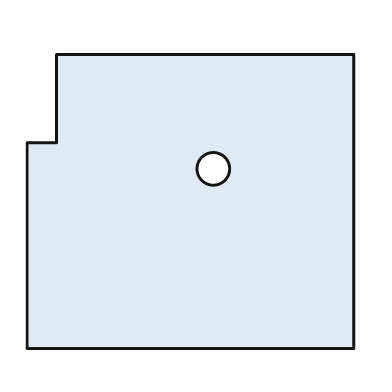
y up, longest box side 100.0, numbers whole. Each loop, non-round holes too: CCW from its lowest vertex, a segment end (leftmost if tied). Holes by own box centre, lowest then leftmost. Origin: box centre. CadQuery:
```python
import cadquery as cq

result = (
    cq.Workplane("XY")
    .moveTo(-50.0, -45.0)
    .lineTo(50.0, -45.0)
    .lineTo(50.0, 45.0)
    .lineTo(-41.0, 45.0)
    .lineTo(-41.0, 18.0)
    .lineTo(-50.0, 18.0)
    .close()
    .moveTo(7.0, 10.0)
    .circle(5.0)
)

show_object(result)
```